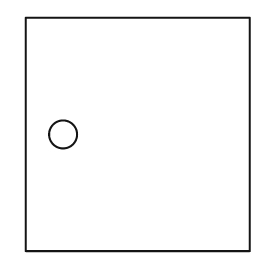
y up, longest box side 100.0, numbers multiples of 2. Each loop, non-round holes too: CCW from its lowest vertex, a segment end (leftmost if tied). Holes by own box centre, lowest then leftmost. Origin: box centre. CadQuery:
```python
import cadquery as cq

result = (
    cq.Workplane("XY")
    .moveTo(-48.0, -50.0)
    .lineTo(48.0, -50.0)
    .lineTo(48.0, 50.0)
    .lineTo(-48.0, 50.0)
    .close()
    .moveTo(-32.0, 0.0)
    .circle(6.0)
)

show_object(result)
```